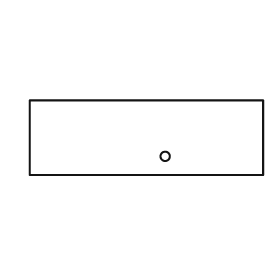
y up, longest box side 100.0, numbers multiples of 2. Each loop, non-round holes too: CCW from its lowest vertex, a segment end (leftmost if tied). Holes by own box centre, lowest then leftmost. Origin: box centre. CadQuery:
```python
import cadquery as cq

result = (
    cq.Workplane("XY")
    .moveTo(-50.0, -16.0)
    .lineTo(50.0, -16.0)
    .lineTo(50.0, 16.0)
    .lineTo(-50.0, 16.0)
    .close()
    .moveTo(8.0, -8.0)
    .circle(2.0)
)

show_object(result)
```